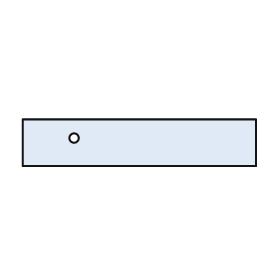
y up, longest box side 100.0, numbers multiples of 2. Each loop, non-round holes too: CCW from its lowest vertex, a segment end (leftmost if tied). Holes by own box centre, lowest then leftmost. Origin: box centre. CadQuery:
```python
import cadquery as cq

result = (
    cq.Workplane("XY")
    .moveTo(-50.0, -10.0)
    .lineTo(50.0, -10.0)
    .lineTo(50.0, 10.0)
    .lineTo(-50.0, 10.0)
    .close()
    .moveTo(-28.0, 2.0)
    .circle(2.0)
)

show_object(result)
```